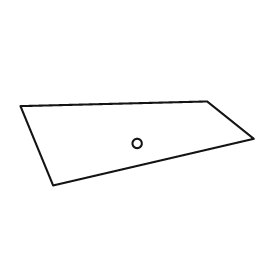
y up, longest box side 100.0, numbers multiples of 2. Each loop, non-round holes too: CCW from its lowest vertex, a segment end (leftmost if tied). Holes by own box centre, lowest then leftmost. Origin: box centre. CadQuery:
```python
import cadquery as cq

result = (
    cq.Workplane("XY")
    .moveTo(-36.0, -18.0)
    .lineTo(50.0, 2.0)
    .lineTo(30.0, 18.0)
    .lineTo(-50.0, 16.0)
    .close()
    .moveTo(0.0, 0.0)
    .circle(2.0)
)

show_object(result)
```